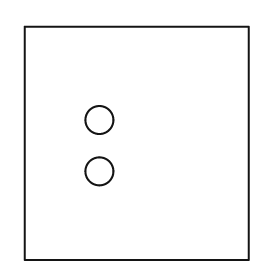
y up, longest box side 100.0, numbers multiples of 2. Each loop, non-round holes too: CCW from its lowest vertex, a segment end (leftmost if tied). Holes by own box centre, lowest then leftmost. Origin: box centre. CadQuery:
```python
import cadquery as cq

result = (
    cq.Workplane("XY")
    .moveTo(-48.0, -50.0)
    .lineTo(48.0, -50.0)
    .lineTo(48.0, 50.0)
    .lineTo(-48.0, 50.0)
    .close()
    .moveTo(-16.0, -12.0)
    .circle(6.0)
    .moveTo(-16.0, 10.0)
    .circle(6.0)
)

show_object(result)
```